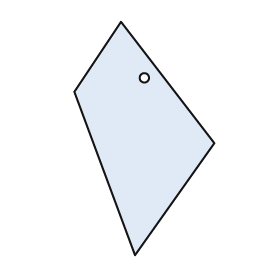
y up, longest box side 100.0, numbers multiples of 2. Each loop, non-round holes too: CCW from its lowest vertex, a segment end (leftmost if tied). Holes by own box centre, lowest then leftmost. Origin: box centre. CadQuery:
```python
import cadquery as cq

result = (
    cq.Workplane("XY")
    .moveTo(-4.0, -50.0)
    .lineTo(30.0, -2.0)
    .lineTo(-10.0, 50.0)
    .lineTo(-30.0, 20.0)
    .close()
    .moveTo(0.0, 26.0)
    .circle(2.0)
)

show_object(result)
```